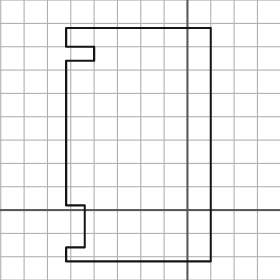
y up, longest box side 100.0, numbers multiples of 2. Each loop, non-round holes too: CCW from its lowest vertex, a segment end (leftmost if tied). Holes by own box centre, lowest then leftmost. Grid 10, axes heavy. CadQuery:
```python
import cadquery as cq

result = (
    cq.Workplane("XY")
    .moveTo(-52.0, -22.0)
    .lineTo(10.0, -22.0)
    .lineTo(10.0, 78.0)
    .lineTo(-52.0, 78.0)
    .lineTo(-52.0, 70.0)
    .lineTo(-40.0, 70.0)
    .lineTo(-40.0, 64.0)
    .lineTo(-52.0, 64.0)
    .lineTo(-52.0, 2.0)
    .lineTo(-44.0, 2.0)
    .lineTo(-44.0, -16.0)
    .lineTo(-52.0, -16.0)
    .close()
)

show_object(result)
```